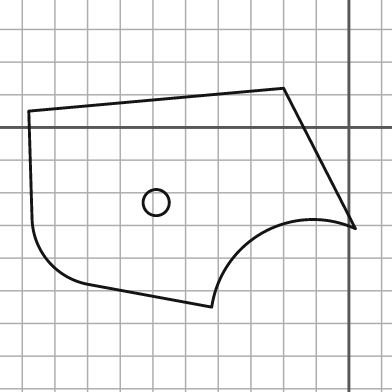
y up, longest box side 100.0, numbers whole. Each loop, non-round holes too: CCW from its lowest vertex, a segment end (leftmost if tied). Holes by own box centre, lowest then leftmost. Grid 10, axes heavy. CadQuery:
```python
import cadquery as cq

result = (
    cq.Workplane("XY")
    .moveTo(-42.0, -55.0)
    .threePointArc((-26.0, -32.0), (2.0, -31.0))
    .lineTo(-20.0, 12.0)
    .lineTo(-98.0, 5.0)
    .lineTo(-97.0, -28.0)
    .threePointArc((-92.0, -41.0), (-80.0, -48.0))
    .close()
    .moveTo(-59.0, -23.0)
    .circle(4.0)
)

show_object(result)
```